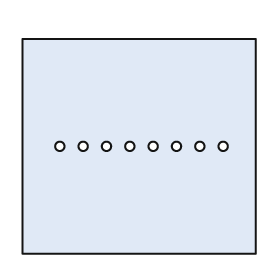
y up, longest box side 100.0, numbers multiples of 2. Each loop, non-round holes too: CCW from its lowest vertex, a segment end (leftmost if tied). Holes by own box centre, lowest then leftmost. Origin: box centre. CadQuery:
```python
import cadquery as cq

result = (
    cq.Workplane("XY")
    .moveTo(-50.0, -46.0)
    .lineTo(50.0, -46.0)
    .lineTo(50.0, 46.0)
    .lineTo(-50.0, 46.0)
    .close()
    .moveTo(-34.0, 0.0)
    .circle(2.0)
    .moveTo(-24.0, 0.0)
    .circle(2.0)
    .moveTo(-14.0, 0.0)
    .circle(2.0)
    .moveTo(-4.0, 0.0)
    .circle(2.0)
    .moveTo(6.0, 0.0)
    .circle(2.0)
    .moveTo(16.0, 0.0)
    .circle(2.0)
    .moveTo(26.0, 0.0)
    .circle(2.0)
    .moveTo(36.0, 0.0)
    .circle(2.0)
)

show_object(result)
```